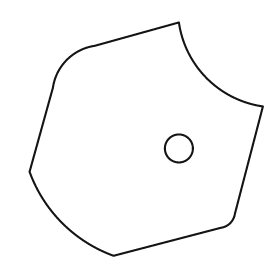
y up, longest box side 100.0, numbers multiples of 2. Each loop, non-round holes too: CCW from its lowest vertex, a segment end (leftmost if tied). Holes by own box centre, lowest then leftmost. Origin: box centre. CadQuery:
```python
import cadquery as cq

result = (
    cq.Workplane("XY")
    .moveTo(-14.0, -50.0)
    .lineTo(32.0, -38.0)
    .threePointArc((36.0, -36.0), (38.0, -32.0))
    .lineTo(50.0, 14.0)
    .threePointArc((26.0, 26.0), (14.0, 50.0))
    .lineTo(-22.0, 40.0)
    .threePointArc((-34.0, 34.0), (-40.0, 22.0))
    .lineTo(-50.0, -14.0)
    .threePointArc((-36.0, -36.0), (-14.0, -50.0))
    .close()
    .moveTo(14.0, -4.0)
    .circle(6.0)
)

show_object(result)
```